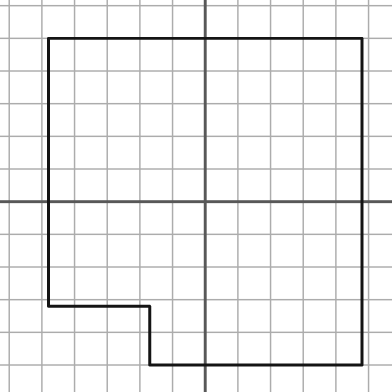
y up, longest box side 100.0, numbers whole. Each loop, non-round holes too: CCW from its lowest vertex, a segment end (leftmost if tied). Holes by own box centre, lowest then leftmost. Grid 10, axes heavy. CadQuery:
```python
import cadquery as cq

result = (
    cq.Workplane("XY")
    .moveTo(-17.0, -50.0)
    .lineTo(48.0, -50.0)
    .lineTo(48.0, 50.0)
    .lineTo(-48.0, 50.0)
    .lineTo(-48.0, -32.0)
    .lineTo(-17.0, -32.0)
    .close()
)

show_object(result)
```